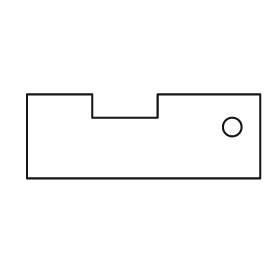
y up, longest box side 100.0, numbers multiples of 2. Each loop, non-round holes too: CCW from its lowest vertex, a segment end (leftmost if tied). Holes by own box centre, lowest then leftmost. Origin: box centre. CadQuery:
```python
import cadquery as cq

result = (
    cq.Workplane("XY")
    .moveTo(-50.0, -18.0)
    .lineTo(50.0, -18.0)
    .lineTo(50.0, 18.0)
    .lineTo(6.0, 18.0)
    .lineTo(6.0, 8.0)
    .lineTo(-22.0, 8.0)
    .lineTo(-22.0, 18.0)
    .lineTo(-50.0, 18.0)
    .close()
    .moveTo(38.0, 4.0)
    .circle(4.0)
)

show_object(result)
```